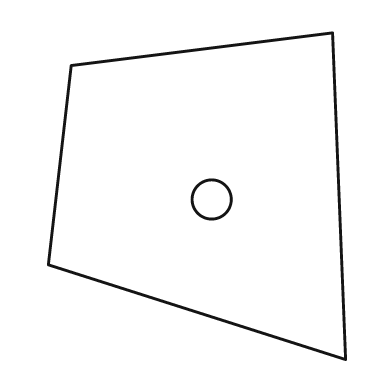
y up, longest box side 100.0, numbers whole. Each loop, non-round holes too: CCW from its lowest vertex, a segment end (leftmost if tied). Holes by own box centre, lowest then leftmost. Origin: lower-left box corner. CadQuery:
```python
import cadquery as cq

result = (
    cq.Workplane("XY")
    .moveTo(91.0, 0.0)
    .lineTo(87.0, 100.0)
    .lineTo(7.0, 90.0)
    .lineTo(0.0, 29.0)
    .close()
    .moveTo(50.0, 49.0)
    .circle(6.0)
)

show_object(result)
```